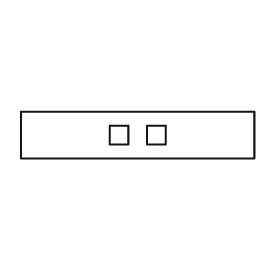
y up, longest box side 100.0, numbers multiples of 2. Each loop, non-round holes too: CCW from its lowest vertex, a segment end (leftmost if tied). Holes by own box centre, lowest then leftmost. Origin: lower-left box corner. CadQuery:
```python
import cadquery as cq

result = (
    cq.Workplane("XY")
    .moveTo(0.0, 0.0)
    .lineTo(100.0, 0.0)
    .lineTo(100.0, 20.0)
    .lineTo(0.0, 20.0)
    .close()
    .moveTo(38.0, 6.0)
    .lineTo(46.0, 6.0)
    .lineTo(46.0, 14.0)
    .lineTo(38.0, 14.0)
    .close()
    .moveTo(54.0, 6.0)
    .lineTo(62.0, 6.0)
    .lineTo(62.0, 14.0)
    .lineTo(54.0, 14.0)
    .close()
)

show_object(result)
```